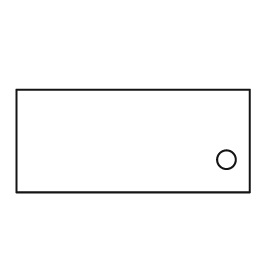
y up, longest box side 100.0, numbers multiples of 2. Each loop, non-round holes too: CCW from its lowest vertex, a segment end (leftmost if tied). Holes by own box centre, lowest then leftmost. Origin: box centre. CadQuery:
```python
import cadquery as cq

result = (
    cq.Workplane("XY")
    .moveTo(-50.0, -22.0)
    .lineTo(50.0, -22.0)
    .lineTo(50.0, 22.0)
    .lineTo(-50.0, 22.0)
    .close()
    .moveTo(40.0, -8.0)
    .circle(4.0)
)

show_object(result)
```